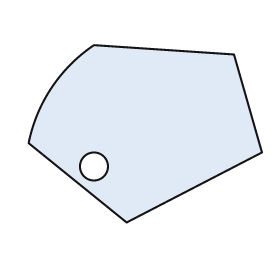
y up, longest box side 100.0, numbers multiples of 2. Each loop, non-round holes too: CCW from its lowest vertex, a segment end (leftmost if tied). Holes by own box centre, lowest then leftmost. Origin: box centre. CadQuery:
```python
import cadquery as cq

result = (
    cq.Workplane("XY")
    .moveTo(-8.0, -38.0)
    .lineTo(50.0, -8.0)
    .lineTo(38.0, 34.0)
    .lineTo(-22.0, 38.0)
    .threePointArc((-40.0, 20.0), (-50.0, -4.0))
    .close()
    .moveTo(-22.0, -14.0)
    .circle(6.0)
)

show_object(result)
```